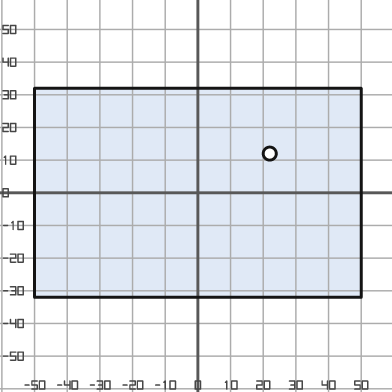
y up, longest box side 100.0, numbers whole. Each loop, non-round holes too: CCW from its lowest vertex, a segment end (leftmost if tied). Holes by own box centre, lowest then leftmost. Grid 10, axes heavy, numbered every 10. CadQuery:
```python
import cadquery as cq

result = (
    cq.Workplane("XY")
    .moveTo(-50.0, -32.0)
    .lineTo(50.0, -32.0)
    .lineTo(50.0, 32.0)
    .lineTo(-50.0, 32.0)
    .close()
    .moveTo(22.0, 12.0)
    .circle(2.0)
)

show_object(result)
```